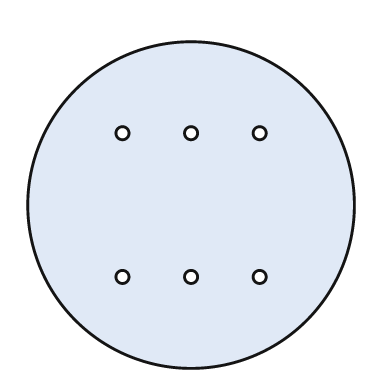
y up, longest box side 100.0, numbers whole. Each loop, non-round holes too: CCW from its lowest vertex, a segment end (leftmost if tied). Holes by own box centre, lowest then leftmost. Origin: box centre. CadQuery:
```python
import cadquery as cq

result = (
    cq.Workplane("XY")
    .moveTo(0.0, 0.0)
    .circle(50.0)
    .moveTo(-21.0, -22.0)
    .circle(2.0)
    .moveTo(0.0, -22.0)
    .circle(2.0)
    .moveTo(21.0, -22.0)
    .circle(2.0)
    .moveTo(-21.0, 22.0)
    .circle(2.0)
    .moveTo(0.0, 22.0)
    .circle(2.0)
    .moveTo(21.0, 22.0)
    .circle(2.0)
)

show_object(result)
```